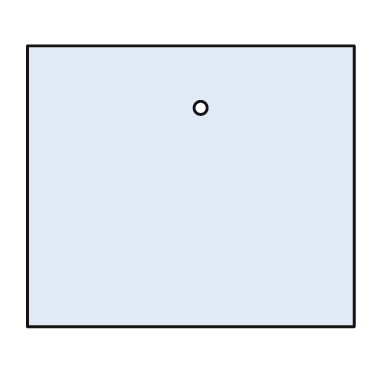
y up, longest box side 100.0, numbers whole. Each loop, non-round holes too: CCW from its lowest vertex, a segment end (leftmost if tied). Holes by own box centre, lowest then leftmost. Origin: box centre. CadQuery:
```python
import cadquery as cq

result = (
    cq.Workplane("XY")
    .moveTo(-50.0, -43.0)
    .lineTo(50.0, -43.0)
    .lineTo(50.0, 43.0)
    .lineTo(-50.0, 43.0)
    .close()
    .moveTo(3.0, 24.0)
    .circle(2.0)
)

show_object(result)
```